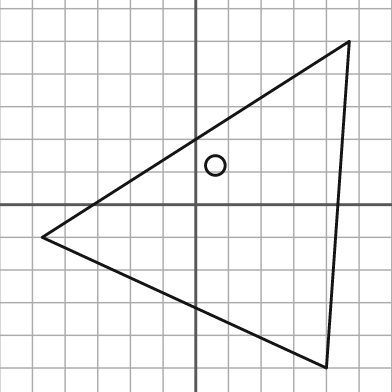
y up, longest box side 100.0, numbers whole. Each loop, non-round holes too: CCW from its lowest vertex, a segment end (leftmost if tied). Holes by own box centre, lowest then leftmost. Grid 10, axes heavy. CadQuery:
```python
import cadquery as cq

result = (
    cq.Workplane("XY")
    .moveTo(40.0, -50.0)
    .lineTo(47.0, 50.0)
    .lineTo(-47.0, -10.0)
    .close()
    .moveTo(6.0, 12.0)
    .circle(3.0)
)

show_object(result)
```